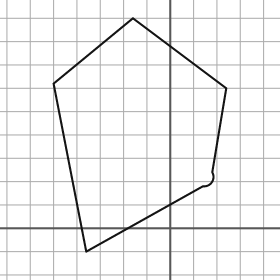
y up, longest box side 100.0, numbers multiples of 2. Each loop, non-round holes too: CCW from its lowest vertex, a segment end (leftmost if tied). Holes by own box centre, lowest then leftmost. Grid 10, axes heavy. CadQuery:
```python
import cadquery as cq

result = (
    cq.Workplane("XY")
    .moveTo(-36.0, -10.0)
    .lineTo(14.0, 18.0)
    .threePointArc((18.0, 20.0), (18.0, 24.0))
    .lineTo(24.0, 60.0)
    .lineTo(-16.0, 90.0)
    .lineTo(-50.0, 62.0)
    .close()
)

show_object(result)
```